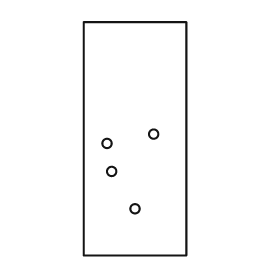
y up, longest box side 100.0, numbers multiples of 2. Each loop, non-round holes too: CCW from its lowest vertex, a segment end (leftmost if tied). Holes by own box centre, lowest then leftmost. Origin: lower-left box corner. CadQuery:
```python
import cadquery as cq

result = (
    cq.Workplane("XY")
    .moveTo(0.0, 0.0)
    .lineTo(44.0, 0.0)
    .lineTo(44.0, 100.0)
    .lineTo(0.0, 100.0)
    .close()
    .moveTo(22.0, 20.0)
    .circle(2.0)
    .moveTo(12.0, 36.0)
    .circle(2.0)
    .moveTo(10.0, 48.0)
    .circle(2.0)
    .moveTo(30.0, 52.0)
    .circle(2.0)
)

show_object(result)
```